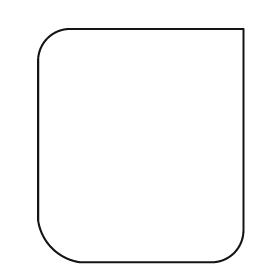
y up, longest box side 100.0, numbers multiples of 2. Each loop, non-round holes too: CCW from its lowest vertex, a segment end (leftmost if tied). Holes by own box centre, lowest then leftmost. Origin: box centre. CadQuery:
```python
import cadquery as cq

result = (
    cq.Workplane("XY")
    .moveTo(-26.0, -50.0)
    .lineTo(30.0, -50.0)
    .threePointArc((40.0, -46.0), (44.0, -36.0))
    .lineTo(44.0, 50.0)
    .lineTo(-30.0, 50.0)
    .threePointArc((-40.0, 46.0), (-44.0, 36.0))
    .lineTo(-44.0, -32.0)
    .threePointArc((-38.0, -44.0), (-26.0, -50.0))
    .close()
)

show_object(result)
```